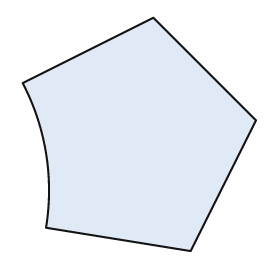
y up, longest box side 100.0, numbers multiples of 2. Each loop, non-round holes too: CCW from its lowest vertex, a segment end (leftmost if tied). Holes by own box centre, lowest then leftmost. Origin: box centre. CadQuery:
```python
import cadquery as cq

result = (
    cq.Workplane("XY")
    .moveTo(22.0, -50.0)
    .lineTo(50.0, 6.0)
    .lineTo(6.0, 50.0)
    .lineTo(-50.0, 22.0)
    .threePointArc((-40.0, -8.0), (-40.0, -40.0))
    .close()
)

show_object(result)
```